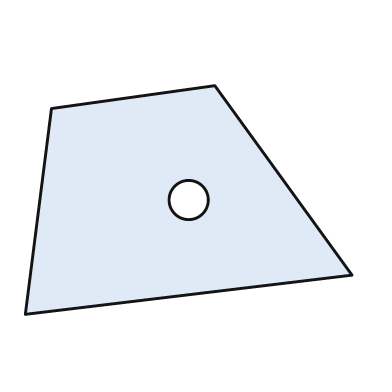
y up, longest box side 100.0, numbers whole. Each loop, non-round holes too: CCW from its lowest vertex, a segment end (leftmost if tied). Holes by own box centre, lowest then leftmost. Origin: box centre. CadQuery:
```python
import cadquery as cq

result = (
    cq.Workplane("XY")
    .moveTo(-50.0, -35.0)
    .lineTo(50.0, -23.0)
    .lineTo(8.0, 35.0)
    .lineTo(-42.0, 28.0)
    .close()
    .moveTo(0.0, 0.0)
    .circle(6.0)
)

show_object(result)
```